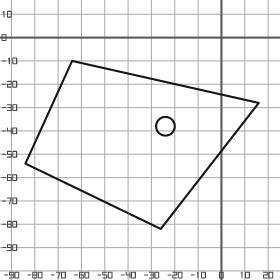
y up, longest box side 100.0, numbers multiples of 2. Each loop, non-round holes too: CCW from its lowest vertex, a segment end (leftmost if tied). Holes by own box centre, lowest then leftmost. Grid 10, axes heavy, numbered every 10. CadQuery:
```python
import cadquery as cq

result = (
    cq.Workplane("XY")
    .moveTo(-26.0, -82.0)
    .lineTo(16.0, -28.0)
    .lineTo(-64.0, -10.0)
    .lineTo(-84.0, -54.0)
    .close()
    .moveTo(-24.0, -38.0)
    .circle(4.0)
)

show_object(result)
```